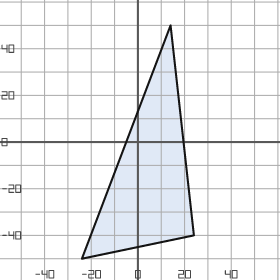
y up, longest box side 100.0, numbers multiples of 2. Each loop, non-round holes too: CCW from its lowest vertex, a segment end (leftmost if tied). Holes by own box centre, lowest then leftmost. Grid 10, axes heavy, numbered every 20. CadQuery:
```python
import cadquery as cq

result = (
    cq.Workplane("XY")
    .moveTo(-24.0, -50.0)
    .lineTo(24.0, -40.0)
    .lineTo(14.0, 50.0)
    .close()
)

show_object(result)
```